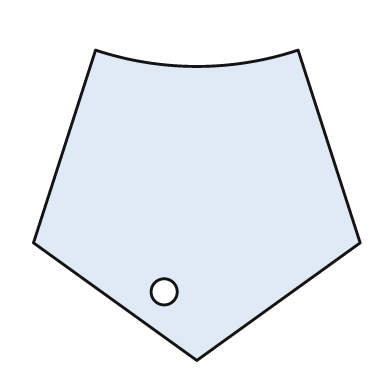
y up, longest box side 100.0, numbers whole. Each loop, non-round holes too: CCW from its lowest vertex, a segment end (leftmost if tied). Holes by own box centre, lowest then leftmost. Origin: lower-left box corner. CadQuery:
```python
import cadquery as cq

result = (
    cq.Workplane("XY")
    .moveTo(50.0, 0.0)
    .lineTo(100.0, 36.0)
    .lineTo(81.0, 95.0)
    .threePointArc((50.0, 90.0), (19.0, 95.0))
    .lineTo(0.0, 36.0)
    .close()
    .moveTo(40.0, 21.0)
    .circle(4.0)
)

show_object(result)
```